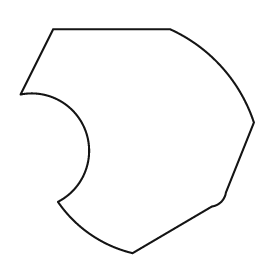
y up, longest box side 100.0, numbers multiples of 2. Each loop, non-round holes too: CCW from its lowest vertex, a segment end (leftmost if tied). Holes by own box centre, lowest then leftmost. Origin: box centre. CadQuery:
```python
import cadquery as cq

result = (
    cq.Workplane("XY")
    .moveTo(-2.0, -48.0)
    .lineTo(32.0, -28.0)
    .threePointArc((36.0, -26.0), (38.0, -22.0))
    .lineTo(50.0, 8.0)
    .threePointArc((36.0, 32.0), (14.0, 48.0))
    .lineTo(-36.0, 48.0)
    .lineTo(-50.0, 20.0)
    .threePointArc((-22.0, 4.0), (-34.0, -26.0))
    .threePointArc((-20.0, -40.0), (-2.0, -48.0))
    .close()
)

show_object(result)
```